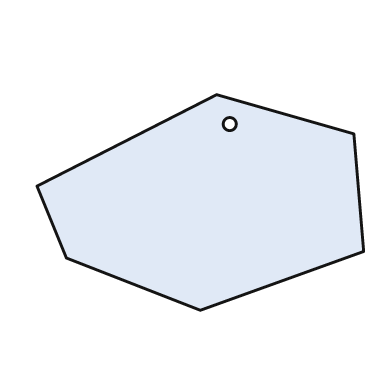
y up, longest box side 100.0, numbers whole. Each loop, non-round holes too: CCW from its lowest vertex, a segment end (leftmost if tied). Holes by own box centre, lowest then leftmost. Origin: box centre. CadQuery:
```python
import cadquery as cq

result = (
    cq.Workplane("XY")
    .moveTo(0.0, -33.0)
    .lineTo(50.0, -15.0)
    .lineTo(47.0, 21.0)
    .lineTo(5.0, 33.0)
    .lineTo(-50.0, 5.0)
    .lineTo(-41.0, -17.0)
    .close()
    .moveTo(9.0, 24.0)
    .circle(2.0)
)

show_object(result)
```